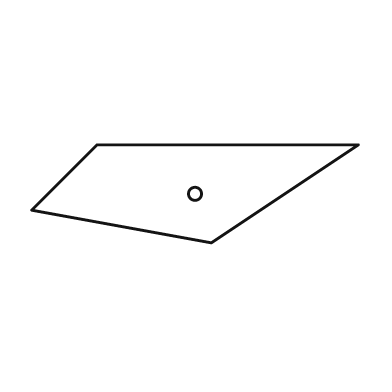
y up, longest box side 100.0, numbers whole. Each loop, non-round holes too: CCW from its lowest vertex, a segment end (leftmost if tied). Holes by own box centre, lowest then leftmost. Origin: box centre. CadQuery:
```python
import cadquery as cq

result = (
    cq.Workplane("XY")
    .moveTo(5.0, -15.0)
    .lineTo(50.0, 15.0)
    .lineTo(-30.0, 15.0)
    .lineTo(-50.0, -5.0)
    .close()
    .moveTo(0.0, 0.0)
    .circle(2.0)
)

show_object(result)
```